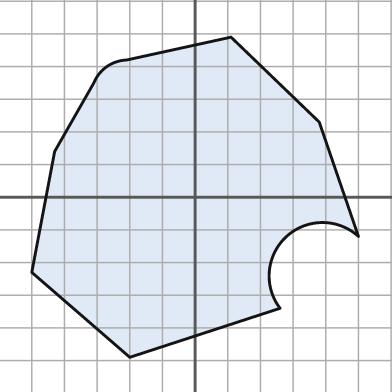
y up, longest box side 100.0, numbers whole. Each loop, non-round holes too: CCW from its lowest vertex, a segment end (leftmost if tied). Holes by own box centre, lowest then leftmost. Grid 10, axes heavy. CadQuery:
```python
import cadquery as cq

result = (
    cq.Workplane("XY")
    .moveTo(-20.0, -49.0)
    .lineTo(26.0, -34.0)
    .threePointArc((28.0, -12.0), (50.0, -12.0))
    .lineTo(38.0, 23.0)
    .lineTo(11.0, 49.0)
    .lineTo(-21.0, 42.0)
    .threePointArc((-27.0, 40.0), (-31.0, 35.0))
    .lineTo(-43.0, 14.0)
    .lineTo(-50.0, -23.0)
    .close()
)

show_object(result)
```